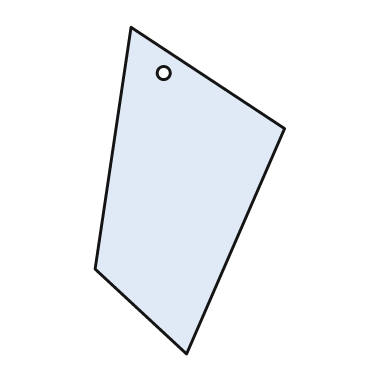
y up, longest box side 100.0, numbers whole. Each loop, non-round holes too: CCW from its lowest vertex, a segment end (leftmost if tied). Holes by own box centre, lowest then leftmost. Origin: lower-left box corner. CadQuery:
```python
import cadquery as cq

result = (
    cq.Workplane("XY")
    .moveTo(28.0, 0.0)
    .lineTo(58.0, 69.0)
    .lineTo(11.0, 100.0)
    .lineTo(0.0, 26.0)
    .close()
    .moveTo(21.0, 86.0)
    .circle(2.0)
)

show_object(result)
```